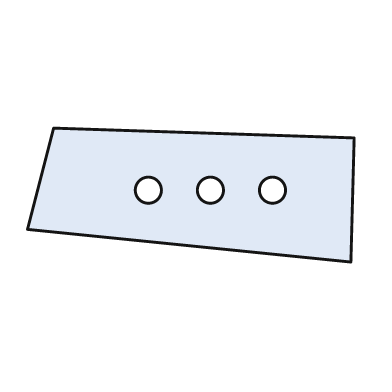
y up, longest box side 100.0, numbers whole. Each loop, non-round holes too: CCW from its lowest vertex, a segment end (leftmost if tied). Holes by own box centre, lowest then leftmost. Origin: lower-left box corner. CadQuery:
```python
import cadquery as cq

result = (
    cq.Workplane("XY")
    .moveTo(99.0, 0.0)
    .lineTo(100.0, 38.0)
    .lineTo(8.0, 41.0)
    .lineTo(0.0, 10.0)
    .close()
    .moveTo(37.0, 22.0)
    .circle(4.0)
    .moveTo(56.0, 22.0)
    .circle(4.0)
    .moveTo(75.0, 22.0)
    .circle(4.0)
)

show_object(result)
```